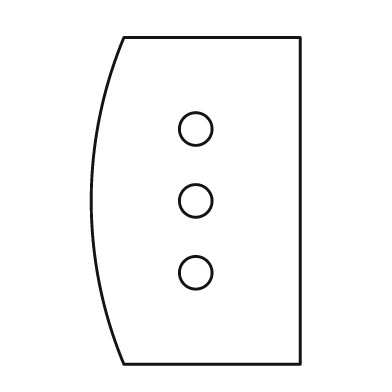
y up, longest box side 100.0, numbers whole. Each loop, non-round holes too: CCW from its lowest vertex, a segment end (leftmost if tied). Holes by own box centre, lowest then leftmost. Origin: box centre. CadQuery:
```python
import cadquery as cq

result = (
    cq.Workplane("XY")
    .moveTo(-22.0, -50.0)
    .lineTo(32.0, -50.0)
    .lineTo(32.0, 50.0)
    .lineTo(-22.0, 50.0)
    .threePointArc((-32.0, 0.0), (-22.0, -50.0))
    .close()
    .moveTo(0.0, -22.0)
    .circle(5.0)
    .moveTo(0.0, 0.0)
    .circle(5.0)
    .moveTo(0.0, 22.0)
    .circle(5.0)
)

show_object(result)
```